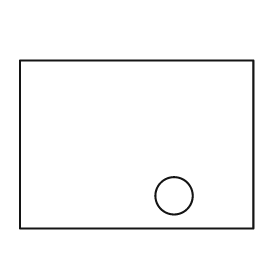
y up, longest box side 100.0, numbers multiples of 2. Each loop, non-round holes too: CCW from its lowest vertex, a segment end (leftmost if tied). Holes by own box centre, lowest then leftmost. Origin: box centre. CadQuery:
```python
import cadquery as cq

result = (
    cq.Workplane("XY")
    .moveTo(-50.0, -36.0)
    .lineTo(50.0, -36.0)
    .lineTo(50.0, 36.0)
    .lineTo(-50.0, 36.0)
    .close()
    .moveTo(16.0, -22.0)
    .circle(8.0)
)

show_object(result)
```